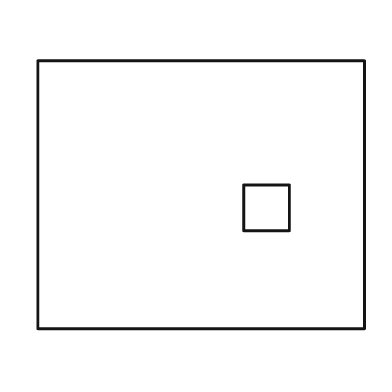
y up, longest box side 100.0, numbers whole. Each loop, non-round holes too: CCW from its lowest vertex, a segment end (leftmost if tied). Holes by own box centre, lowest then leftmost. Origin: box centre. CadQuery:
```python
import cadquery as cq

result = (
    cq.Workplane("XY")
    .moveTo(-50.0, -41.0)
    .lineTo(50.0, -41.0)
    .lineTo(50.0, 41.0)
    .lineTo(-50.0, 41.0)
    .close()
    .moveTo(13.0, -11.0)
    .lineTo(27.0, -11.0)
    .lineTo(27.0, 3.0)
    .lineTo(13.0, 3.0)
    .close()
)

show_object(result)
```